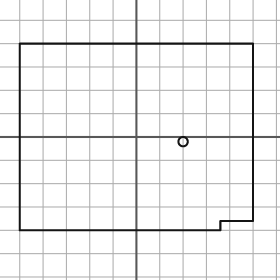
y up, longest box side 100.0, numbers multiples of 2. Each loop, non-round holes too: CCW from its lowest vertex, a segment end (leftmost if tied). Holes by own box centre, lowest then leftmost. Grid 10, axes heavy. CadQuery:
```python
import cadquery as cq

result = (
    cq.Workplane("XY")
    .moveTo(-50.0, -40.0)
    .lineTo(36.0, -40.0)
    .lineTo(36.0, -36.0)
    .lineTo(50.0, -36.0)
    .lineTo(50.0, 40.0)
    .lineTo(-50.0, 40.0)
    .close()
    .moveTo(20.0, -2.0)
    .circle(2.0)
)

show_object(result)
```